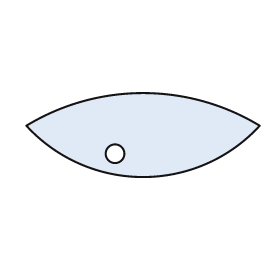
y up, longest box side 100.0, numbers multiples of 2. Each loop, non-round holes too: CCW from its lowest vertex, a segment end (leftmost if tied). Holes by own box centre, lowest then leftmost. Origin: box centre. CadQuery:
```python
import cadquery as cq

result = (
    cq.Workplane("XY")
    .moveTo(-50.0, 4.0)
    .threePointArc((0.0, -18.0), (50.0, 4.0))
    .threePointArc((0.0, 18.0), (-50.0, 4.0))
    .close()
    .moveTo(-12.0, -8.0)
    .circle(4.0)
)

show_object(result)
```